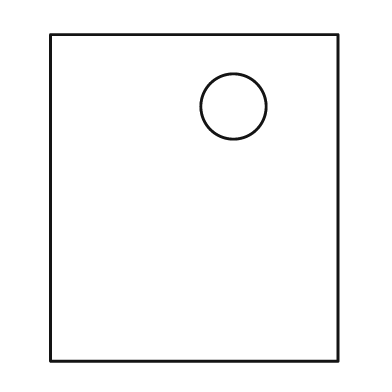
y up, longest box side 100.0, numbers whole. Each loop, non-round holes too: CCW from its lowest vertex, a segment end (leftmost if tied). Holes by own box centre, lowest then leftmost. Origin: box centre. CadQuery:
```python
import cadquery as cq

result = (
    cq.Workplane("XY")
    .moveTo(-44.0, -50.0)
    .lineTo(44.0, -50.0)
    .lineTo(44.0, 50.0)
    .lineTo(-44.0, 50.0)
    .close()
    .moveTo(12.0, 28.0)
    .circle(10.0)
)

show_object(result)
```